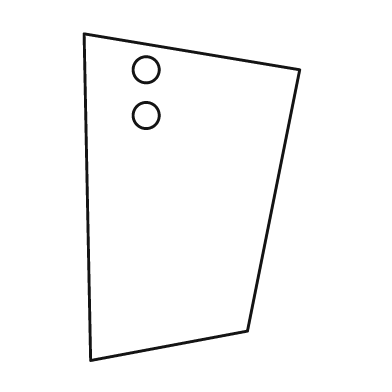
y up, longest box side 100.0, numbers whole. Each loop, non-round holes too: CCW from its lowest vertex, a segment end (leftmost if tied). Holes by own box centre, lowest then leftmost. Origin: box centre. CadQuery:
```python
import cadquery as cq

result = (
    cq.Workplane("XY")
    .moveTo(-31.0, -50.0)
    .lineTo(17.0, -41.0)
    .lineTo(33.0, 39.0)
    .lineTo(-33.0, 50.0)
    .close()
    .moveTo(-14.0, 25.0)
    .circle(4.0)
    .moveTo(-14.0, 39.0)
    .circle(4.0)
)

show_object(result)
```